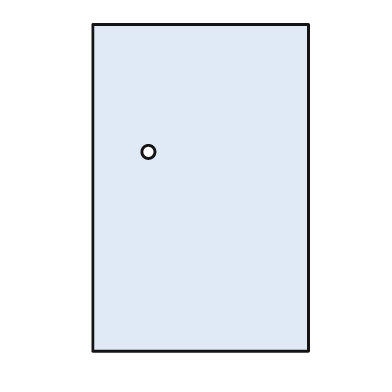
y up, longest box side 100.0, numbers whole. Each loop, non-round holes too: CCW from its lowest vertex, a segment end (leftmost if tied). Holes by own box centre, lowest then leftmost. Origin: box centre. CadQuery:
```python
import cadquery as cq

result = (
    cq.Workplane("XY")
    .moveTo(-33.0, -50.0)
    .lineTo(33.0, -50.0)
    .lineTo(33.0, 50.0)
    .lineTo(-33.0, 50.0)
    .close()
    .moveTo(-16.0, 11.0)
    .circle(2.0)
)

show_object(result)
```